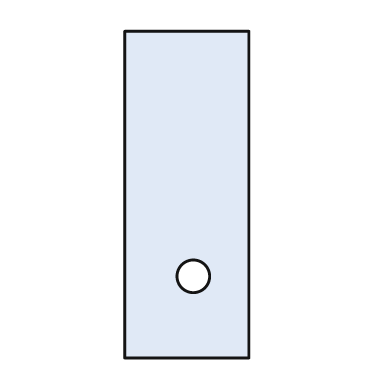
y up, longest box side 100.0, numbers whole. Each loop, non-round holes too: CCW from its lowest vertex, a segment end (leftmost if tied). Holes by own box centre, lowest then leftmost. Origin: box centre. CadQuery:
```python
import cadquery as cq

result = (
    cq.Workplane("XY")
    .moveTo(-19.0, -50.0)
    .lineTo(19.0, -50.0)
    .lineTo(19.0, 50.0)
    .lineTo(-19.0, 50.0)
    .close()
    .moveTo(2.0, -25.0)
    .circle(5.0)
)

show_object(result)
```